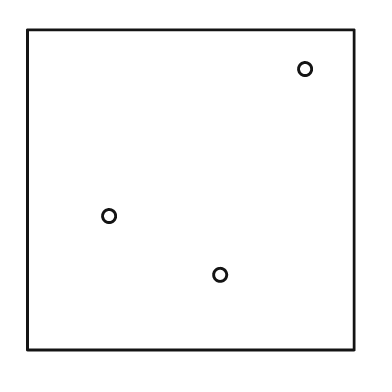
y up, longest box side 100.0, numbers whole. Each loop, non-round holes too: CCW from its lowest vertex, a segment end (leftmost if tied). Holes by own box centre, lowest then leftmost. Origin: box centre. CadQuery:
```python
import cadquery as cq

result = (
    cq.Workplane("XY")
    .moveTo(-50.0, -49.0)
    .lineTo(50.0, -49.0)
    .lineTo(50.0, 49.0)
    .lineTo(-50.0, 49.0)
    .close()
    .moveTo(9.0, -26.0)
    .circle(2.0)
    .moveTo(-25.0, -8.0)
    .circle(2.0)
    .moveTo(35.0, 37.0)
    .circle(2.0)
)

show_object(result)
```